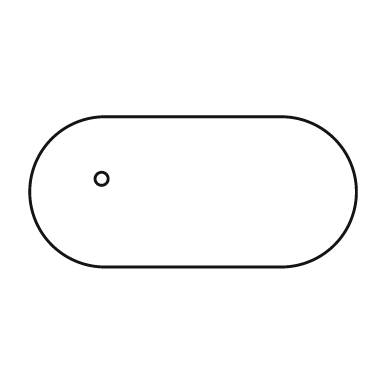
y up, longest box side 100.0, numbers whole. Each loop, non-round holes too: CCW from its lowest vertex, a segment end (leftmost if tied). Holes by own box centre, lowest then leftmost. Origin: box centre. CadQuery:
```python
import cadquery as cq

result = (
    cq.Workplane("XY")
    .moveTo(-27.0, -23.0)
    .lineTo(27.0, -23.0)
    .threePointArc((50.0, 0.0), (27.0, 23.0))
    .lineTo(-27.0, 23.0)
    .threePointArc((-50.0, 0.0), (-27.0, -23.0))
    .close()
    .moveTo(-28.0, 4.0)
    .circle(2.0)
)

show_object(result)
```